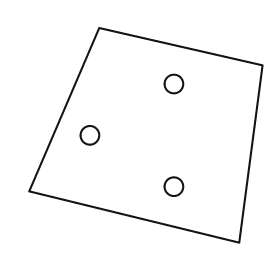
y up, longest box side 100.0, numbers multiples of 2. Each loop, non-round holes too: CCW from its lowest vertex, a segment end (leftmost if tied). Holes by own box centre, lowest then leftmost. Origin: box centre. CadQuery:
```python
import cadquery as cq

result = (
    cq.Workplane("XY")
    .moveTo(40.0, -46.0)
    .lineTo(50.0, 30.0)
    .lineTo(-20.0, 46.0)
    .lineTo(-50.0, -24.0)
    .close()
    .moveTo(12.0, -22.0)
    .circle(4.0)
    .moveTo(-24.0, 0.0)
    .circle(4.0)
    .moveTo(12.0, 22.0)
    .circle(4.0)
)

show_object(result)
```